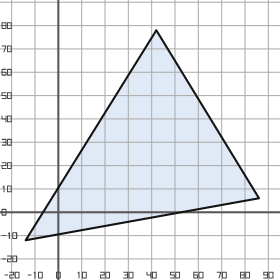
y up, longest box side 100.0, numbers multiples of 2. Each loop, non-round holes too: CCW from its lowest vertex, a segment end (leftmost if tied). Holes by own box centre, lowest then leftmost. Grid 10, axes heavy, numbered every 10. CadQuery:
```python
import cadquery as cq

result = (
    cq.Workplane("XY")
    .moveTo(-14.0, -12.0)
    .lineTo(86.0, 6.0)
    .lineTo(42.0, 78.0)
    .close()
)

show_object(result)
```